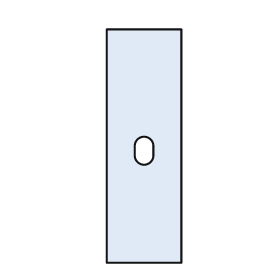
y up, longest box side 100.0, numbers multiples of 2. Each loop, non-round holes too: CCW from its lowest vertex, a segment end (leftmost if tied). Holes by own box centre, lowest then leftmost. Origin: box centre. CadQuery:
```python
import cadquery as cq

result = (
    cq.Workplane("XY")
    .moveTo(-16.0, -50.0)
    .lineTo(16.0, -50.0)
    .lineTo(16.0, 50.0)
    .lineTo(-16.0, 50.0)
    .close()
    .moveTo(-4.0, -4.0)
    .threePointArc((0.0, -8.0), (4.0, -4.0))
    .lineTo(4.0, 0.0)
    .threePointArc((0.0, 4.0), (-4.0, 0.0))
    .close()
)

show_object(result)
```